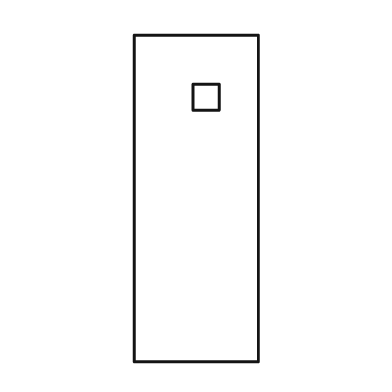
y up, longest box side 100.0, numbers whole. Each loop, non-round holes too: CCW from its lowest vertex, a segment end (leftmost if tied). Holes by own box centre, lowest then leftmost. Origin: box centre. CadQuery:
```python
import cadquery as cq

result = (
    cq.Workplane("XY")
    .moveTo(-19.0, -50.0)
    .lineTo(19.0, -50.0)
    .lineTo(19.0, 50.0)
    .lineTo(-19.0, 50.0)
    .close()
    .moveTo(-1.0, 27.0)
    .lineTo(7.0, 27.0)
    .lineTo(7.0, 35.0)
    .lineTo(-1.0, 35.0)
    .close()
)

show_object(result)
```